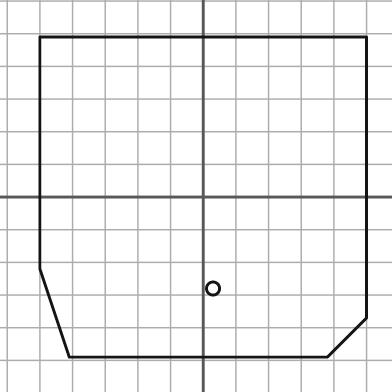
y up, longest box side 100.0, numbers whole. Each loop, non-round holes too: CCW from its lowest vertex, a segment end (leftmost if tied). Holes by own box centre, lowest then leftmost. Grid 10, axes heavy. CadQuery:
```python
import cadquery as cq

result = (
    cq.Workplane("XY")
    .moveTo(-41.0, -49.0)
    .lineTo(38.0, -49.0)
    .lineTo(50.0, -37.0)
    .lineTo(50.0, 49.0)
    .lineTo(-50.0, 49.0)
    .lineTo(-50.0, -22.0)
    .close()
    .moveTo(3.0, -28.0)
    .circle(2.0)
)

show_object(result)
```